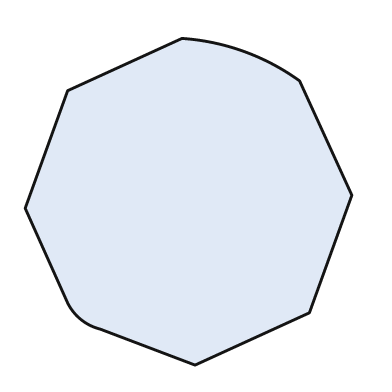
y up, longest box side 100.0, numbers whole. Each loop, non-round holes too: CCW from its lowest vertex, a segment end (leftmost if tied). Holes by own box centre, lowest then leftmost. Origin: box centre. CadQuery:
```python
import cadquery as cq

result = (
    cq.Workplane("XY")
    .moveTo(2.0, -50.0)
    .lineTo(37.0, -34.0)
    .lineTo(50.0, 2.0)
    .lineTo(34.0, 37.0)
    .threePointArc((17.0, 46.0), (-2.0, 50.0))
    .lineTo(-37.0, 34.0)
    .lineTo(-50.0, -2.0)
    .lineTo(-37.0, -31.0)
    .threePointArc((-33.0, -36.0), (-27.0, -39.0))
    .close()
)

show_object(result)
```